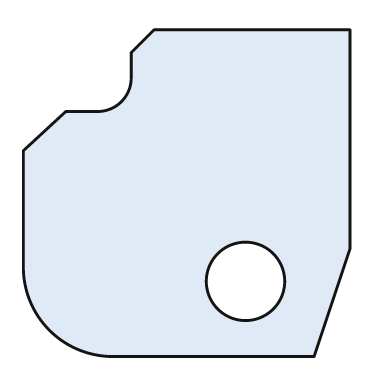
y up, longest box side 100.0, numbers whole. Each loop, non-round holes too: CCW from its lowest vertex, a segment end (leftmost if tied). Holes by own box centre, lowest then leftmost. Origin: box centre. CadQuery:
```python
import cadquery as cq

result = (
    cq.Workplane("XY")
    .moveTo(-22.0, -50.0)
    .lineTo(39.0, -50.0)
    .lineTo(50.0, -17.0)
    .lineTo(50.0, 50.0)
    .lineTo(-10.0, 50.0)
    .lineTo(-17.0, 43.0)
    .lineTo(-17.0, 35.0)
    .threePointArc((-20.0, 28.0), (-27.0, 25.0))
    .lineTo(-37.0, 25.0)
    .lineTo(-50.0, 13.0)
    .lineTo(-50.0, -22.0)
    .threePointArc((-42.0, -42.0), (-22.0, -50.0))
    .close()
    .moveTo(18.0, -27.0)
    .circle(12.0)
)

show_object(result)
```